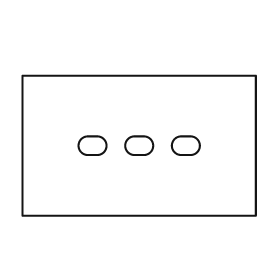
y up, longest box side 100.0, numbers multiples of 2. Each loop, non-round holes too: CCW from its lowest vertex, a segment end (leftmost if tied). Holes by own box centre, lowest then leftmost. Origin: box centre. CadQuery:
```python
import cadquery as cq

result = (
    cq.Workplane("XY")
    .moveTo(-50.0, -30.0)
    .lineTo(50.0, -30.0)
    .lineTo(50.0, 30.0)
    .lineTo(-50.0, 30.0)
    .close()
    .moveTo(-22.0, -4.0)
    .lineTo(-18.0, -4.0)
    .threePointArc((-14.0, 0.0), (-18.0, 4.0))
    .lineTo(-22.0, 4.0)
    .threePointArc((-26.0, 0.0), (-22.0, -4.0))
    .close()
    .moveTo(-2.0, -4.0)
    .lineTo(2.0, -4.0)
    .threePointArc((6.0, 0.0), (2.0, 4.0))
    .lineTo(-2.0, 4.0)
    .threePointArc((-6.0, 0.0), (-2.0, -4.0))
    .close()
    .moveTo(18.0, -4.0)
    .lineTo(22.0, -4.0)
    .threePointArc((26.0, 0.0), (22.0, 4.0))
    .lineTo(18.0, 4.0)
    .threePointArc((14.0, 0.0), (18.0, -4.0))
    .close()
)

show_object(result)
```